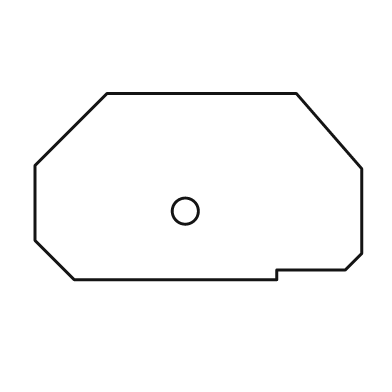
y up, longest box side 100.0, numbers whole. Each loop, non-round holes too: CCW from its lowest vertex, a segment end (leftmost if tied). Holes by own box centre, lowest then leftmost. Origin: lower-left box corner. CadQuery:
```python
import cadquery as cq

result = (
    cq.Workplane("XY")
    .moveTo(12.0, 0.0)
    .lineTo(74.0, 0.0)
    .lineTo(74.0, 3.0)
    .lineTo(95.0, 3.0)
    .lineTo(100.0, 8.0)
    .lineTo(100.0, 34.0)
    .lineTo(80.0, 57.0)
    .lineTo(22.0, 57.0)
    .lineTo(0.0, 35.0)
    .lineTo(0.0, 12.0)
    .close()
    .moveTo(46.0, 21.0)
    .circle(4.0)
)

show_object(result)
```